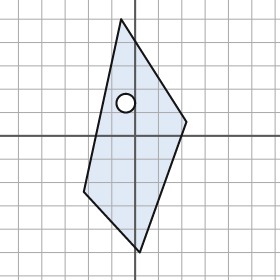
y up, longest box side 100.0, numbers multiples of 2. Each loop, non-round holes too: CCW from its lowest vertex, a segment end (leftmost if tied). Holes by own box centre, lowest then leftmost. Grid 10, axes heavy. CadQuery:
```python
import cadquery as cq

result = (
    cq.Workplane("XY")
    .moveTo(2.0, -50.0)
    .lineTo(22.0, 6.0)
    .lineTo(-6.0, 50.0)
    .lineTo(-22.0, -24.0)
    .close()
    .moveTo(-4.0, 14.0)
    .circle(4.0)
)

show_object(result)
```